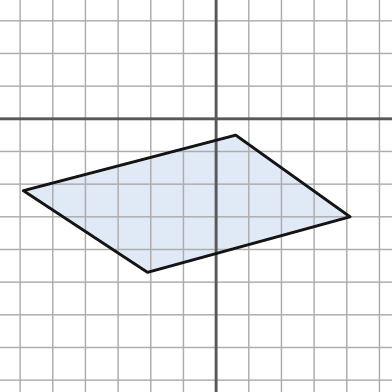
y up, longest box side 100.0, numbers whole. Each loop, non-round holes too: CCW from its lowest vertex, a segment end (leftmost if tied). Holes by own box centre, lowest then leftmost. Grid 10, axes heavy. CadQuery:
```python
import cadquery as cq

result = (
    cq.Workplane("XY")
    .moveTo(-21.0, -47.0)
    .lineTo(41.0, -30.0)
    .lineTo(6.0, -5.0)
    .lineTo(-59.0, -22.0)
    .close()
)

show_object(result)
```